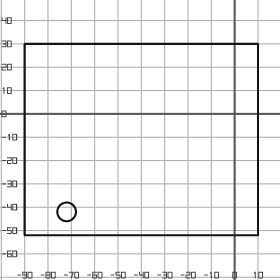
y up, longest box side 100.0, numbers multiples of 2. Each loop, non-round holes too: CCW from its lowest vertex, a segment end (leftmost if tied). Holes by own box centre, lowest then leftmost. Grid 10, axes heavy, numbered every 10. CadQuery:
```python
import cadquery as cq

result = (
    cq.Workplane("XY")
    .moveTo(-90.0, -52.0)
    .lineTo(10.0, -52.0)
    .lineTo(10.0, 30.0)
    .lineTo(-90.0, 30.0)
    .close()
    .moveTo(-72.0, -42.0)
    .circle(4.0)
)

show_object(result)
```